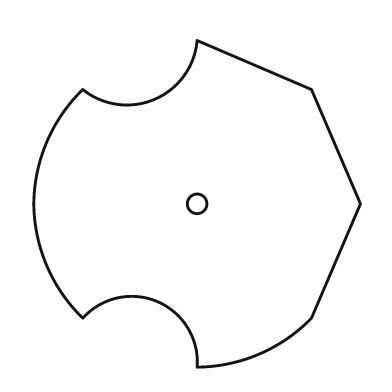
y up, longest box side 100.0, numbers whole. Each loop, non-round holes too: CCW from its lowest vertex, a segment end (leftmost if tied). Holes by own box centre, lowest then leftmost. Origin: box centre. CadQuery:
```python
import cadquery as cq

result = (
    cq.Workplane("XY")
    .moveTo(0.0, -50.0)
    .threePointArc((19.0, -46.0), (35.0, -35.0))
    .lineTo(50.0, 0.0)
    .lineTo(35.0, 35.0)
    .lineTo(0.0, 50.0)
    .threePointArc((-13.0, 32.0), (-35.0, 35.0))
    .threePointArc((-46.0, 19.0), (-50.0, 0.0))
    .threePointArc((-46.0, -19.0), (-35.0, -35.0))
    .threePointArc((-12.0, -30.0), (0.0, -50.0))
    .close()
    .moveTo(0.0, 0.0)
    .circle(3.0)
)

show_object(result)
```